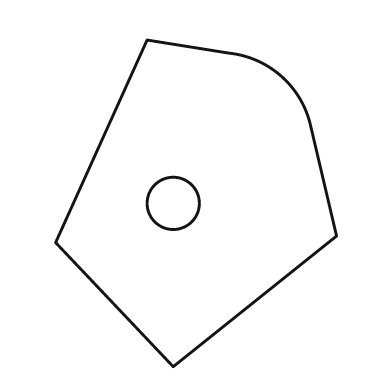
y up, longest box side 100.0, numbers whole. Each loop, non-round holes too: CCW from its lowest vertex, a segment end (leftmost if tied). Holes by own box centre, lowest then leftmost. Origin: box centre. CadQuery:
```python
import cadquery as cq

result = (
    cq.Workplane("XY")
    .moveTo(-7.0, -50.0)
    .lineTo(43.0, -10.0)
    .lineTo(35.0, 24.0)
    .threePointArc((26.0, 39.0), (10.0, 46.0))
    .lineTo(-15.0, 50.0)
    .lineTo(-43.0, -12.0)
    .close()
    .moveTo(-7.0, 0.0)
    .circle(8.0)
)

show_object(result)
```